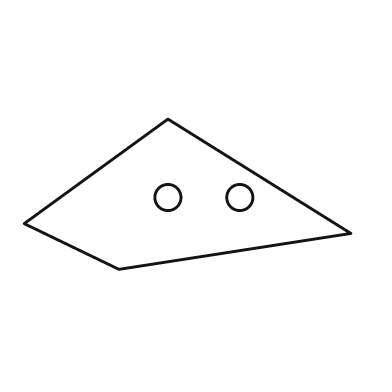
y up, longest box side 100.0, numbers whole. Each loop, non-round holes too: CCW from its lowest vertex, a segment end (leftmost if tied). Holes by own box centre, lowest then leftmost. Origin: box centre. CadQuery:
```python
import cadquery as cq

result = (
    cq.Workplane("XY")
    .moveTo(-21.0, -23.0)
    .lineTo(50.0, -12.0)
    .lineTo(-6.0, 23.0)
    .lineTo(-50.0, -9.0)
    .close()
    .moveTo(-6.0, -1.0)
    .circle(4.0)
    .moveTo(16.0, -1.0)
    .circle(4.0)
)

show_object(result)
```